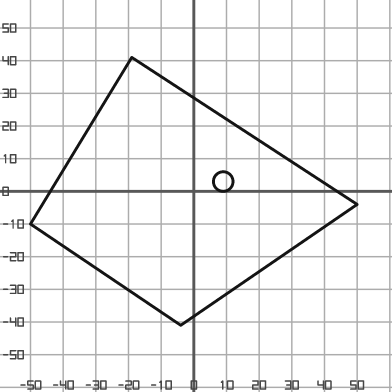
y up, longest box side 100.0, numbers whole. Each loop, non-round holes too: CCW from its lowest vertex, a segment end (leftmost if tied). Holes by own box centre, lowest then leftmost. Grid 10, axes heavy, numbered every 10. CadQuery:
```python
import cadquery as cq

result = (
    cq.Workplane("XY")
    .moveTo(-4.0, -41.0)
    .lineTo(50.0, -4.0)
    .lineTo(-19.0, 41.0)
    .lineTo(-50.0, -10.0)
    .close()
    .moveTo(9.0, 3.0)
    .circle(3.0)
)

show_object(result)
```